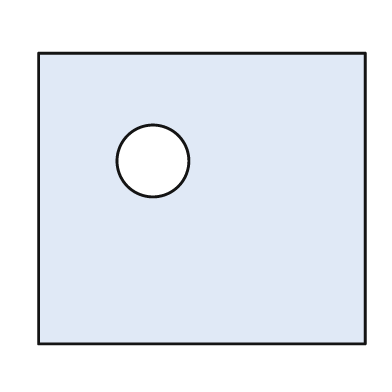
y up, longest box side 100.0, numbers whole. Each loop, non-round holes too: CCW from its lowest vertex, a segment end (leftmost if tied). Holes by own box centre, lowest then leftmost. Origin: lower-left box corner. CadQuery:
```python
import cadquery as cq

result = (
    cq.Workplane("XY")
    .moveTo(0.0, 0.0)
    .lineTo(100.0, 0.0)
    .lineTo(100.0, 89.0)
    .lineTo(0.0, 89.0)
    .close()
    .moveTo(35.0, 56.0)
    .circle(11.0)
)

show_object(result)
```